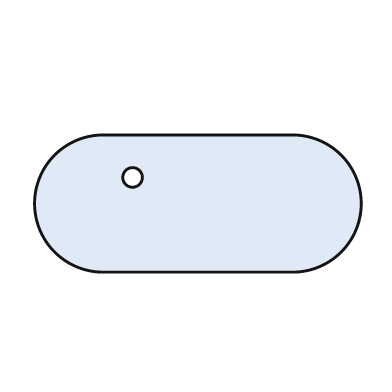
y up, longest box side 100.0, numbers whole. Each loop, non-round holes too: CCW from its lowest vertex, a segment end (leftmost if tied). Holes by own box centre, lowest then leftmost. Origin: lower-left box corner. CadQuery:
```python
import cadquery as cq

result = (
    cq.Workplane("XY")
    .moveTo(21.0, 0.0)
    .lineTo(79.0, 0.0)
    .threePointArc((100.0, 21.0), (79.0, 42.0))
    .lineTo(21.0, 42.0)
    .threePointArc((0.0, 21.0), (21.0, 0.0))
    .close()
    .moveTo(30.0, 29.0)
    .circle(3.0)
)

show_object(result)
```